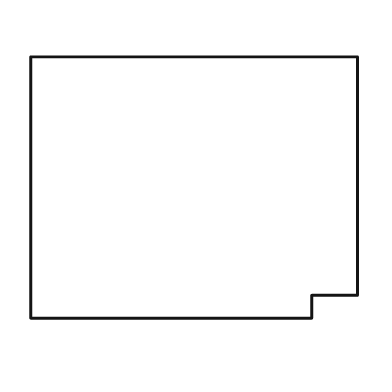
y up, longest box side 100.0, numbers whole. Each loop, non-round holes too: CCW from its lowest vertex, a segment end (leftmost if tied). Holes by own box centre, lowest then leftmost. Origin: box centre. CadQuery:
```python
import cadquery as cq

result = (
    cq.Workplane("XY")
    .moveTo(-50.0, -40.0)
    .lineTo(36.0, -40.0)
    .lineTo(36.0, -33.0)
    .lineTo(50.0, -33.0)
    .lineTo(50.0, 40.0)
    .lineTo(-50.0, 40.0)
    .close()
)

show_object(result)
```